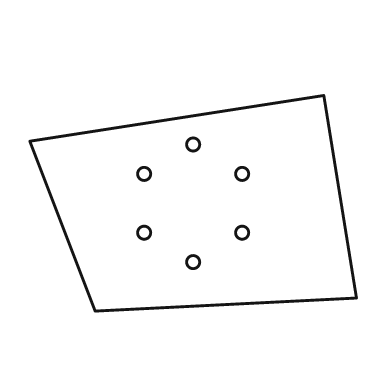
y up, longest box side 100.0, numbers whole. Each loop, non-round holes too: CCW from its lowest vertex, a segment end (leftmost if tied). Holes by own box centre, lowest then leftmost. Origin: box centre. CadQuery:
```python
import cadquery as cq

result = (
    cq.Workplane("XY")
    .moveTo(-30.0, -33.0)
    .lineTo(50.0, -29.0)
    .lineTo(40.0, 33.0)
    .lineTo(-50.0, 19.0)
    .close()
    .moveTo(0.0, -18.0)
    .circle(2.0)
    .moveTo(-15.0, -9.0)
    .circle(2.0)
    .moveTo(15.0, -9.0)
    .circle(2.0)
    .moveTo(-15.0, 9.0)
    .circle(2.0)
    .moveTo(15.0, 9.0)
    .circle(2.0)
    .moveTo(0.0, 18.0)
    .circle(2.0)
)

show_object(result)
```